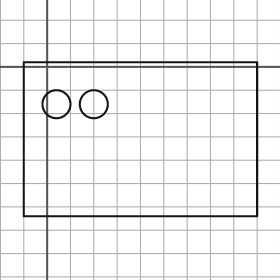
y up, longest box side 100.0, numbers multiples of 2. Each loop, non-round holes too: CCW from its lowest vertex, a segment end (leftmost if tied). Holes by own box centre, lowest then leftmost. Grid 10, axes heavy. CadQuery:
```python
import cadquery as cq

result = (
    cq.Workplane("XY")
    .moveTo(-10.0, -64.0)
    .lineTo(90.0, -64.0)
    .lineTo(90.0, 2.0)
    .lineTo(-10.0, 2.0)
    .close()
    .moveTo(4.0, -16.0)
    .circle(6.0)
    .moveTo(20.0, -16.0)
    .circle(6.0)
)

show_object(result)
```